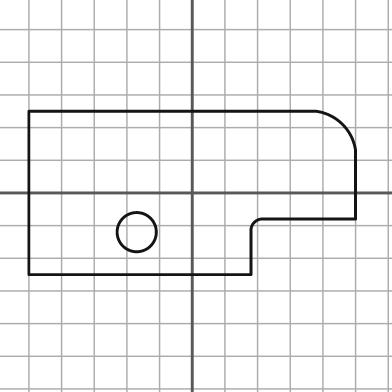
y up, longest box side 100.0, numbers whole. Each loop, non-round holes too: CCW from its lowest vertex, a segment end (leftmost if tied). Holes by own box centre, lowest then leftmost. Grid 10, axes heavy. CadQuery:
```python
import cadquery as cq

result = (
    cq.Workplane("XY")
    .moveTo(-50.0, -25.0)
    .lineTo(18.0, -25.0)
    .lineTo(18.0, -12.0)
    .threePointArc((19.0, -9.0), (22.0, -8.0))
    .lineTo(50.0, -8.0)
    .lineTo(50.0, 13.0)
    .threePointArc((46.0, 21.0), (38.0, 25.0))
    .lineTo(-50.0, 25.0)
    .close()
    .moveTo(-17.0, -12.0)
    .circle(6.0)
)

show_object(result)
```